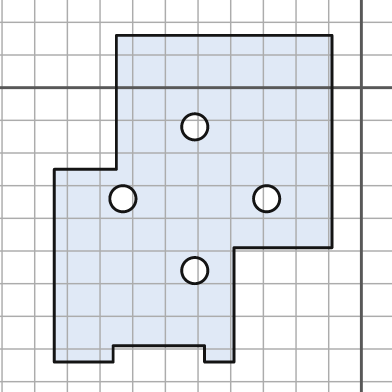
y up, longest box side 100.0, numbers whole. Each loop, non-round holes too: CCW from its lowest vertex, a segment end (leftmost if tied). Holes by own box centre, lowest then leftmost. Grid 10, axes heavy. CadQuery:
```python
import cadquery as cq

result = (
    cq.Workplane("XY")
    .moveTo(-94.0, -84.0)
    .lineTo(-76.0, -84.0)
    .lineTo(-76.0, -79.0)
    .lineTo(-48.0, -79.0)
    .lineTo(-48.0, -84.0)
    .lineTo(-39.0, -84.0)
    .lineTo(-39.0, -49.0)
    .lineTo(-9.0, -49.0)
    .lineTo(-9.0, 16.0)
    .lineTo(-75.0, 16.0)
    .lineTo(-75.0, -25.0)
    .lineTo(-94.0, -25.0)
    .close()
    .moveTo(-51.0, -56.0)
    .circle(4.0)
    .moveTo(-73.0, -34.0)
    .circle(4.0)
    .moveTo(-29.0, -34.0)
    .circle(4.0)
    .moveTo(-51.0, -12.0)
    .circle(4.0)
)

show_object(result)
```